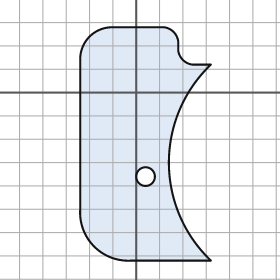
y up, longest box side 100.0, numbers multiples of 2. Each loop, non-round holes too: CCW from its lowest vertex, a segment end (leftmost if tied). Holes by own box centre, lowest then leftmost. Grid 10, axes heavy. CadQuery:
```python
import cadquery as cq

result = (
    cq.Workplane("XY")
    .moveTo(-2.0, -72.0)
    .lineTo(32.0, -72.0)
    .threePointArc((14.0, -30.0), (32.0, 12.0))
    .lineTo(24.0, 12.0)
    .threePointArc((20.0, 14.0), (18.0, 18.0))
    .lineTo(18.0, 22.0)
    .threePointArc((16.0, 26.0), (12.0, 28.0))
    .lineTo(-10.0, 28.0)
    .threePointArc((-20.0, 24.0), (-24.0, 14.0))
    .lineTo(-24.0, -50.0)
    .threePointArc((-18.0, -66.0), (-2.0, -72.0))
    .close()
    .moveTo(4.0, -36.0)
    .circle(4.0)
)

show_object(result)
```